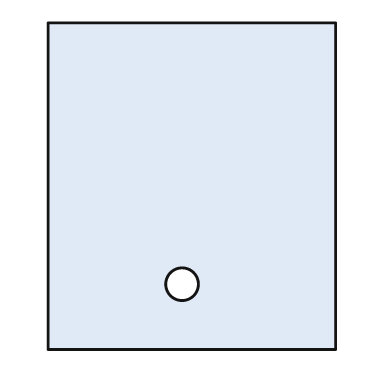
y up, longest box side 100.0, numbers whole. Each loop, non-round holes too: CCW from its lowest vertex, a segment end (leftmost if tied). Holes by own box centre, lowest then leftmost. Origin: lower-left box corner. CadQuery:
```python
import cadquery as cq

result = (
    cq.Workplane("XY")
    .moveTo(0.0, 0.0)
    .lineTo(88.0, 0.0)
    .lineTo(88.0, 100.0)
    .lineTo(0.0, 100.0)
    .close()
    .moveTo(41.0, 20.0)
    .circle(5.0)
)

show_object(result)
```